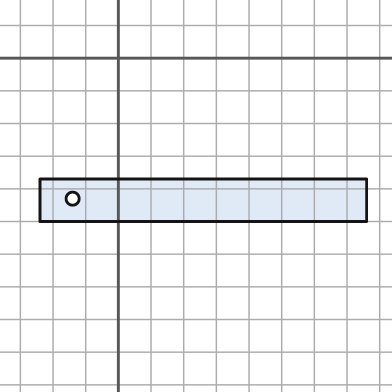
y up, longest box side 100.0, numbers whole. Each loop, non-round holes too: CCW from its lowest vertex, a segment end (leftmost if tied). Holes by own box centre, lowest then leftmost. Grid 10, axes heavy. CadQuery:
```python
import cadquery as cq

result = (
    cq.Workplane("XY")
    .moveTo(-24.0, -50.0)
    .lineTo(76.0, -50.0)
    .lineTo(76.0, -37.0)
    .lineTo(-24.0, -37.0)
    .close()
    .moveTo(-14.0, -43.0)
    .circle(2.0)
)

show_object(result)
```